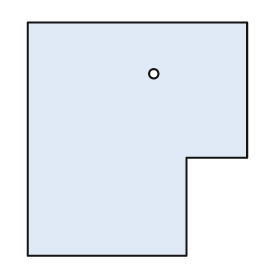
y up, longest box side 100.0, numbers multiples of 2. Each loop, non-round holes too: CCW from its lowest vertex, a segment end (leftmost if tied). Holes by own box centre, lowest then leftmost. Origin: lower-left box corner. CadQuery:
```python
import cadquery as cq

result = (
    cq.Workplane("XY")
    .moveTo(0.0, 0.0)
    .lineTo(68.0, 0.0)
    .lineTo(68.0, 42.0)
    .lineTo(94.0, 42.0)
    .lineTo(94.0, 100.0)
    .lineTo(0.0, 100.0)
    .close()
    .moveTo(54.0, 78.0)
    .circle(2.0)
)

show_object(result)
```